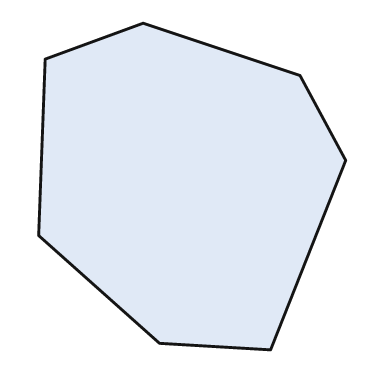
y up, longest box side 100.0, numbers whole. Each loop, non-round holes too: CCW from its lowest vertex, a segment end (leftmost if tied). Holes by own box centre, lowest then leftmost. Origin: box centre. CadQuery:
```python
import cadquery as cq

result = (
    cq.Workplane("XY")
    .moveTo(24.0, -50.0)
    .lineTo(47.0, 8.0)
    .lineTo(33.0, 34.0)
    .lineTo(-15.0, 50.0)
    .lineTo(-45.0, 39.0)
    .lineTo(-47.0, -15.0)
    .lineTo(-10.0, -48.0)
    .close()
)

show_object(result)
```